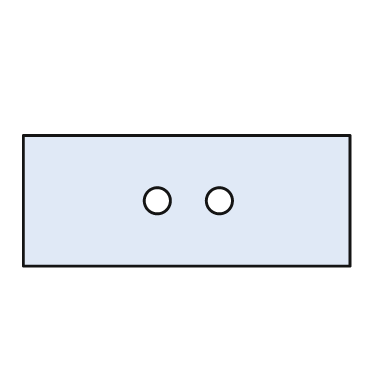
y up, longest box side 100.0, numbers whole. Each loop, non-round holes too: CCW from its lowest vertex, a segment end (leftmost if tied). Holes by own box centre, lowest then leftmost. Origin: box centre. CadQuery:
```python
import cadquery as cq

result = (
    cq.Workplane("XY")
    .moveTo(-50.0, -20.0)
    .lineTo(50.0, -20.0)
    .lineTo(50.0, 20.0)
    .lineTo(-50.0, 20.0)
    .close()
    .moveTo(-9.0, 0.0)
    .circle(4.0)
    .moveTo(10.0, 0.0)
    .circle(4.0)
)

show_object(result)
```